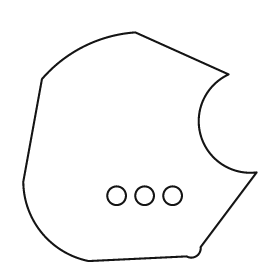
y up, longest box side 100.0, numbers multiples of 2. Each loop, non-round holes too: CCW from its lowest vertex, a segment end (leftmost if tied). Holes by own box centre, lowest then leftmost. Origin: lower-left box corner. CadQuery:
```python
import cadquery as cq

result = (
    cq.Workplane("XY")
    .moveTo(28.0, 0.0)
    .lineTo(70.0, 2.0)
    .threePointArc((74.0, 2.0), (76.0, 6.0))
    .lineTo(100.0, 38.0)
    .threePointArc((76.0, 54.0), (88.0, 80.0))
    .lineTo(48.0, 98.0)
    .threePointArc((26.0, 92.0), (8.0, 78.0))
    .lineTo(0.0, 34.0)
    .threePointArc((8.0, 12.0), (28.0, 0.0))
    .close()
    .moveTo(40.0, 28.0)
    .circle(4.0)
    .moveTo(52.0, 28.0)
    .circle(4.0)
    .moveTo(64.0, 28.0)
    .circle(4.0)
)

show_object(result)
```